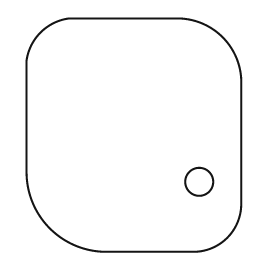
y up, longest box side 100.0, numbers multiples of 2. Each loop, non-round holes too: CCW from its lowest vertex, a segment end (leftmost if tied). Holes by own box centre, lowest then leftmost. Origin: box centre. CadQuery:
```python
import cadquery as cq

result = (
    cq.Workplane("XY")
    .moveTo(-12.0, -50.0)
    .lineTo(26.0, -50.0)
    .threePointArc((40.0, -44.0), (46.0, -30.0))
    .lineTo(46.0, 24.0)
    .threePointArc((38.0, 42.0), (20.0, 50.0))
    .lineTo(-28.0, 50.0)
    .threePointArc((-40.0, 44.0), (-46.0, 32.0))
    .lineTo(-46.0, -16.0)
    .threePointArc((-36.0, -40.0), (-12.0, -50.0))
    .close()
    .moveTo(28.0, -20.0)
    .circle(6.0)
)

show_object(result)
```